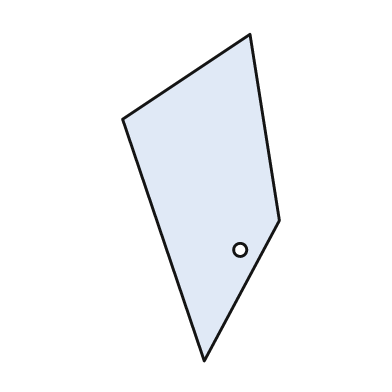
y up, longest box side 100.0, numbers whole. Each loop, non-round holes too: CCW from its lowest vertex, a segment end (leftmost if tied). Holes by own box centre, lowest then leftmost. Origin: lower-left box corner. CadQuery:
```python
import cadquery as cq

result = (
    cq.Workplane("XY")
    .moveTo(25.0, 0.0)
    .lineTo(48.0, 43.0)
    .lineTo(39.0, 100.0)
    .lineTo(0.0, 74.0)
    .close()
    .moveTo(36.0, 34.0)
    .circle(2.0)
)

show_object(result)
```